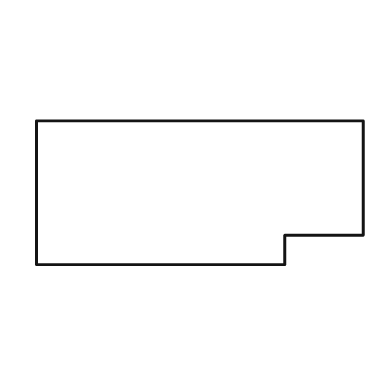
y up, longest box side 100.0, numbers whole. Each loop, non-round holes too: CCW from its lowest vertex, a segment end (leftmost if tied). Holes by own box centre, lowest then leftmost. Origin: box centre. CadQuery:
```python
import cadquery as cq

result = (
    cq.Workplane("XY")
    .moveTo(-50.0, -22.0)
    .lineTo(26.0, -22.0)
    .lineTo(26.0, -13.0)
    .lineTo(50.0, -13.0)
    .lineTo(50.0, 22.0)
    .lineTo(-50.0, 22.0)
    .close()
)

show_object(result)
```